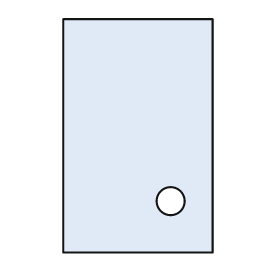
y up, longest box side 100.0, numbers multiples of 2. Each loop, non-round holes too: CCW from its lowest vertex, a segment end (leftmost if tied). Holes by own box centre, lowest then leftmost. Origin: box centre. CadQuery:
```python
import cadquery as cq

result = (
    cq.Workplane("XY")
    .moveTo(-32.0, -50.0)
    .lineTo(32.0, -50.0)
    .lineTo(32.0, 50.0)
    .lineTo(-32.0, 50.0)
    .close()
    .moveTo(14.0, -28.0)
    .circle(6.0)
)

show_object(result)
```